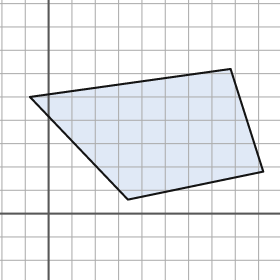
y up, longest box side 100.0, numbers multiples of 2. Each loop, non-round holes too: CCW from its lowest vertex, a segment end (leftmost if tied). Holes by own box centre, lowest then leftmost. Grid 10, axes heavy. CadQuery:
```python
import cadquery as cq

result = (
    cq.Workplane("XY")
    .moveTo(34.0, 6.0)
    .lineTo(92.0, 18.0)
    .lineTo(78.0, 62.0)
    .lineTo(-8.0, 50.0)
    .close()
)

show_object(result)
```